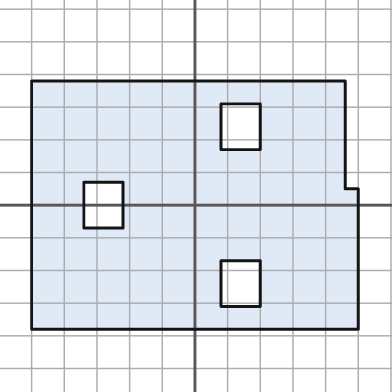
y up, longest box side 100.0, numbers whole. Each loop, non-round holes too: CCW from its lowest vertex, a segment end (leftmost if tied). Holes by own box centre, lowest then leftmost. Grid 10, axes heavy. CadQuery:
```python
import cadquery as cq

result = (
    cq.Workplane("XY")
    .moveTo(-50.0, -38.0)
    .lineTo(50.0, -38.0)
    .lineTo(50.0, 5.0)
    .lineTo(46.0, 5.0)
    .lineTo(46.0, 38.0)
    .lineTo(-50.0, 38.0)
    .close()
    .moveTo(8.0, -31.0)
    .lineTo(20.0, -31.0)
    .lineTo(20.0, -17.0)
    .lineTo(8.0, -17.0)
    .close()
    .moveTo(-34.0, -7.0)
    .lineTo(-22.0, -7.0)
    .lineTo(-22.0, 7.0)
    .lineTo(-34.0, 7.0)
    .close()
    .moveTo(8.0, 17.0)
    .lineTo(20.0, 17.0)
    .lineTo(20.0, 31.0)
    .lineTo(8.0, 31.0)
    .close()
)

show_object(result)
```